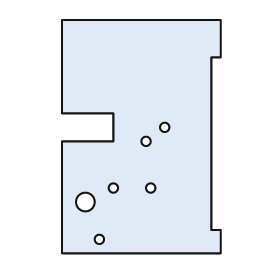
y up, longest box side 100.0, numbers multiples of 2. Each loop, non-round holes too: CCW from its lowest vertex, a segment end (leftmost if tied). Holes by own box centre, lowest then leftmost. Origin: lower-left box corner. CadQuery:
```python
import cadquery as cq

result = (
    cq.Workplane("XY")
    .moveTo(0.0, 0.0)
    .lineTo(68.0, 0.0)
    .lineTo(68.0, 10.0)
    .lineTo(64.0, 10.0)
    .lineTo(64.0, 84.0)
    .lineTo(68.0, 84.0)
    .lineTo(68.0, 100.0)
    .lineTo(0.0, 100.0)
    .lineTo(0.0, 60.0)
    .lineTo(22.0, 60.0)
    .lineTo(22.0, 48.0)
    .lineTo(0.0, 48.0)
    .close()
    .moveTo(16.0, 6.0)
    .circle(2.0)
    .moveTo(10.0, 22.0)
    .circle(4.0)
    .moveTo(22.0, 28.0)
    .circle(2.0)
    .moveTo(38.0, 28.0)
    .circle(2.0)
    .moveTo(36.0, 48.0)
    .circle(2.0)
    .moveTo(44.0, 54.0)
    .circle(2.0)
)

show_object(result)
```